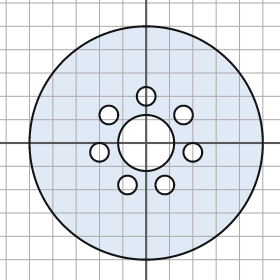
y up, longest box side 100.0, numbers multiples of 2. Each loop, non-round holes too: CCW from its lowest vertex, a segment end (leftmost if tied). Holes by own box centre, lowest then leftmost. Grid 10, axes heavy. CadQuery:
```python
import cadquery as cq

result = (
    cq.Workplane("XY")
    .moveTo(0.0, 0.0)
    .circle(50.0)
    .moveTo(-8.0, -18.0)
    .circle(4.0)
    .moveTo(8.0, -18.0)
    .circle(4.0)
    .moveTo(-20.0, -4.0)
    .circle(4.0)
    .moveTo(20.0, -4.0)
    .circle(4.0)
    .moveTo(0.0, 0.0)
    .circle(12.0)
    .moveTo(-16.0, 12.0)
    .circle(4.0)
    .moveTo(16.0, 12.0)
    .circle(4.0)
    .moveTo(0.0, 20.0)
    .circle(4.0)
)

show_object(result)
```